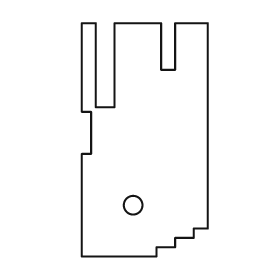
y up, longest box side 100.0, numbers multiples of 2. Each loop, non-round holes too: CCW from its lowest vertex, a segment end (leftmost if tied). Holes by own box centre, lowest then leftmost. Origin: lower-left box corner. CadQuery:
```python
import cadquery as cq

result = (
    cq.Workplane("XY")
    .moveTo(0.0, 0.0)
    .lineTo(32.0, 0.0)
    .lineTo(32.0, 4.0)
    .lineTo(40.0, 4.0)
    .lineTo(40.0, 8.0)
    .lineTo(48.0, 8.0)
    .lineTo(48.0, 12.0)
    .lineTo(54.0, 12.0)
    .lineTo(54.0, 100.0)
    .lineTo(40.0, 100.0)
    .lineTo(40.0, 80.0)
    .lineTo(34.0, 80.0)
    .lineTo(34.0, 100.0)
    .lineTo(14.0, 100.0)
    .lineTo(14.0, 64.0)
    .lineTo(6.0, 64.0)
    .lineTo(6.0, 100.0)
    .lineTo(0.0, 100.0)
    .lineTo(0.0, 62.0)
    .lineTo(4.0, 62.0)
    .lineTo(4.0, 44.0)
    .lineTo(0.0, 44.0)
    .close()
    .moveTo(22.0, 22.0)
    .circle(4.0)
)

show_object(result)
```